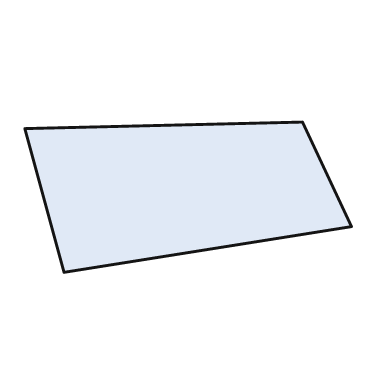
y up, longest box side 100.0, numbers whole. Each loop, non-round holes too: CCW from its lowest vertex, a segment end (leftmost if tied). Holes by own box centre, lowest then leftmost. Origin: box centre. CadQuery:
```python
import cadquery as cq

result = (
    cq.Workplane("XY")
    .moveTo(-38.0, -23.0)
    .lineTo(50.0, -9.0)
    .lineTo(35.0, 23.0)
    .lineTo(-50.0, 21.0)
    .close()
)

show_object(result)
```